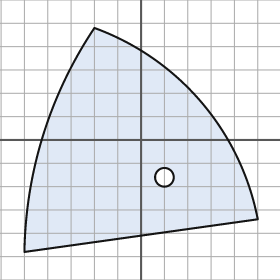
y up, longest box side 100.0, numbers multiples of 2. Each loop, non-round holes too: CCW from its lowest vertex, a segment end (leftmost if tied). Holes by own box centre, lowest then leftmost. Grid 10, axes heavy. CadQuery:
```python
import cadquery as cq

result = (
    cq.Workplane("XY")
    .moveTo(-50.0, -48.0)
    .lineTo(50.0, -34.0)
    .threePointArc((26.0, 16.0), (-20.0, 48.0))
    .threePointArc((-42.0, 2.0), (-50.0, -48.0))
    .close()
    .moveTo(10.0, -16.0)
    .circle(4.0)
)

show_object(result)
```